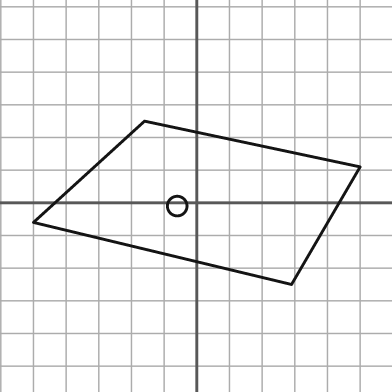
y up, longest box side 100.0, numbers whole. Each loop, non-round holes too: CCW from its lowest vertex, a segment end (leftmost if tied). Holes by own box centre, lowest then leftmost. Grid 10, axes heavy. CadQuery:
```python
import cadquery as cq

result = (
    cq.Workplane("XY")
    .moveTo(29.0, -25.0)
    .lineTo(50.0, 11.0)
    .lineTo(-16.0, 25.0)
    .lineTo(-50.0, -6.0)
    .close()
    .moveTo(-6.0, -1.0)
    .circle(3.0)
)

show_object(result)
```